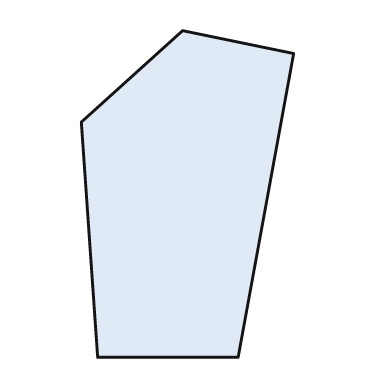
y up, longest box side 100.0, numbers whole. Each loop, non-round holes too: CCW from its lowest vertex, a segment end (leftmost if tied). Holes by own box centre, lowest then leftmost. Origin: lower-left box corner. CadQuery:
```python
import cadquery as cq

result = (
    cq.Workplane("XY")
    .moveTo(5.0, 0.0)
    .lineTo(48.0, 0.0)
    .lineTo(65.0, 93.0)
    .lineTo(31.0, 100.0)
    .lineTo(0.0, 72.0)
    .close()
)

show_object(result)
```